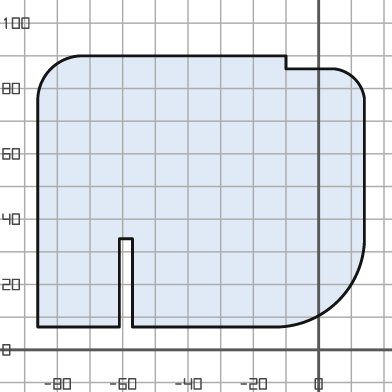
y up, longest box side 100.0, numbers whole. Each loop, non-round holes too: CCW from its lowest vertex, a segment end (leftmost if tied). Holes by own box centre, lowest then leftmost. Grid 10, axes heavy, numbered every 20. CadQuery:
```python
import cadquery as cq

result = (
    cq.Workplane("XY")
    .moveTo(-86.0, 7.0)
    .lineTo(-61.0, 7.0)
    .lineTo(-61.0, 34.0)
    .lineTo(-57.0, 34.0)
    .lineTo(-57.0, 7.0)
    .lineTo(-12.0, 7.0)
    .threePointArc((6.0, 15.0), (14.0, 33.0))
    .lineTo(14.0, 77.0)
    .threePointArc((11.0, 83.0), (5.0, 86.0))
    .lineTo(-10.0, 86.0)
    .lineTo(-10.0, 90.0)
    .lineTo(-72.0, 90.0)
    .threePointArc((-82.0, 86.0), (-86.0, 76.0))
    .close()
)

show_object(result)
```